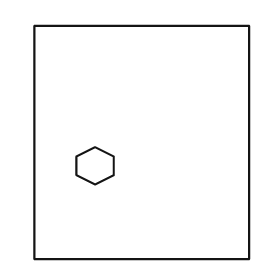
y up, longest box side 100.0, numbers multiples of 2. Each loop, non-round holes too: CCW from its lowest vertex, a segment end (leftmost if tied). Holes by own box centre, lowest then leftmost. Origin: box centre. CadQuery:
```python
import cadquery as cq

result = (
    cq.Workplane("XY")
    .moveTo(-46.0, -50.0)
    .lineTo(46.0, -50.0)
    .lineTo(46.0, 50.0)
    .lineTo(-46.0, 50.0)
    .close()
    .moveTo(-20.0, -18.0)
    .lineTo(-12.0, -14.0)
    .lineTo(-12.0, -6.0)
    .lineTo(-20.0, -2.0)
    .lineTo(-28.0, -6.0)
    .lineTo(-28.0, -14.0)
    .close()
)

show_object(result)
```